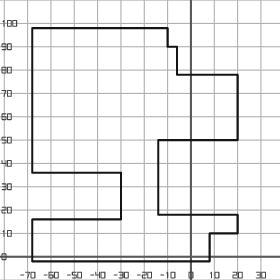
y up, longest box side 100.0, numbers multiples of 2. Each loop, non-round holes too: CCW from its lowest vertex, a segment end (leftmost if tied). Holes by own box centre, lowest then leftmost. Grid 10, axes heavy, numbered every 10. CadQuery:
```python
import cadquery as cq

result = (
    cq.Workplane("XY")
    .moveTo(-68.0, -2.0)
    .lineTo(8.0, -2.0)
    .lineTo(8.0, 10.0)
    .lineTo(20.0, 10.0)
    .lineTo(20.0, 18.0)
    .lineTo(-14.0, 18.0)
    .lineTo(-14.0, 50.0)
    .lineTo(20.0, 50.0)
    .lineTo(20.0, 78.0)
    .lineTo(-6.0, 78.0)
    .lineTo(-6.0, 90.0)
    .lineTo(-10.0, 90.0)
    .lineTo(-10.0, 98.0)
    .lineTo(-68.0, 98.0)
    .lineTo(-68.0, 36.0)
    .lineTo(-30.0, 36.0)
    .lineTo(-30.0, 16.0)
    .lineTo(-68.0, 16.0)
    .close()
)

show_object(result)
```